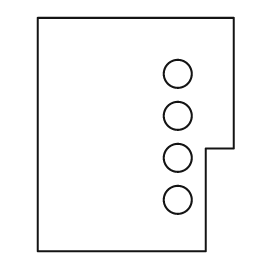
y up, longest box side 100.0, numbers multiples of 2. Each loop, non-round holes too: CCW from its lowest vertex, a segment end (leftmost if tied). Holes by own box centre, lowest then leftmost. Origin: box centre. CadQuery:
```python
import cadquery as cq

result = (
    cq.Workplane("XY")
    .moveTo(-42.0, -50.0)
    .lineTo(30.0, -50.0)
    .lineTo(30.0, -6.0)
    .lineTo(42.0, -6.0)
    .lineTo(42.0, 50.0)
    .lineTo(-42.0, 50.0)
    .close()
    .moveTo(18.0, -28.0)
    .circle(6.0)
    .moveTo(18.0, -10.0)
    .circle(6.0)
    .moveTo(18.0, 8.0)
    .circle(6.0)
    .moveTo(18.0, 26.0)
    .circle(6.0)
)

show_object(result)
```